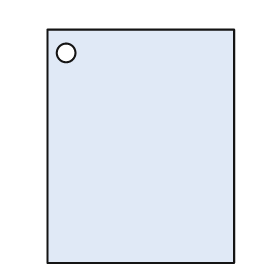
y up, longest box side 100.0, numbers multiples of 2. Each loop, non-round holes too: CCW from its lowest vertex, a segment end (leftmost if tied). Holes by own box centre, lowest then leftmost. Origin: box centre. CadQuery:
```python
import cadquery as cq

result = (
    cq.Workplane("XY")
    .moveTo(-40.0, -50.0)
    .lineTo(40.0, -50.0)
    .lineTo(40.0, 50.0)
    .lineTo(-40.0, 50.0)
    .close()
    .moveTo(-32.0, 40.0)
    .circle(4.0)
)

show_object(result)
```